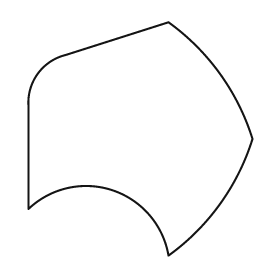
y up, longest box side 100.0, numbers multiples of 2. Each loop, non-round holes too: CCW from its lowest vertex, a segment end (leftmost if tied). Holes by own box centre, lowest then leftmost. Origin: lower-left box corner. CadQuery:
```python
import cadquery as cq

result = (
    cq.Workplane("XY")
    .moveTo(60.0, 0.0)
    .threePointArc((82.0, 22.0), (96.0, 50.0))
    .threePointArc((82.0, 78.0), (60.0, 100.0))
    .lineTo(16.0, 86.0)
    .threePointArc((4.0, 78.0), (0.0, 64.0))
    .lineTo(0.0, 20.0)
    .threePointArc((36.0, 28.0), (60.0, 0.0))
    .close()
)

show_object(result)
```